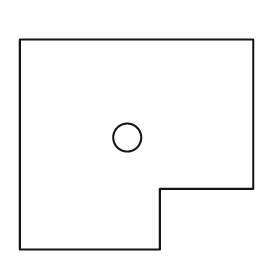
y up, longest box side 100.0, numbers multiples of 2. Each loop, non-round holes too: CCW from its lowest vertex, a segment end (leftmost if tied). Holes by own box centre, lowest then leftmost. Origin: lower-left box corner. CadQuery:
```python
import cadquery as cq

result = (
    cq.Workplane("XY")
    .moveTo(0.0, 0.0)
    .lineTo(60.0, 0.0)
    .lineTo(60.0, 26.0)
    .lineTo(100.0, 26.0)
    .lineTo(100.0, 90.0)
    .lineTo(0.0, 90.0)
    .close()
    .moveTo(46.0, 48.0)
    .circle(6.0)
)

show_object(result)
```